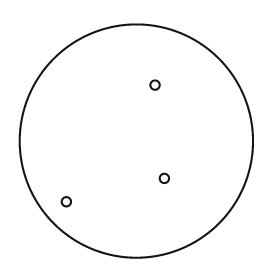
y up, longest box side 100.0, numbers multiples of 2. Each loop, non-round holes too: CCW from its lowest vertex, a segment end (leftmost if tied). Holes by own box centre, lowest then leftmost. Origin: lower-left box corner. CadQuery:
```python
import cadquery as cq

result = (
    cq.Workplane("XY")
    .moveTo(50.0, 50.0)
    .circle(50.0)
    .moveTo(20.0, 24.0)
    .circle(2.0)
    .moveTo(62.0, 34.0)
    .circle(2.0)
    .moveTo(58.0, 74.0)
    .circle(2.0)
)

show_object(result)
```